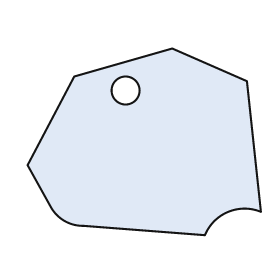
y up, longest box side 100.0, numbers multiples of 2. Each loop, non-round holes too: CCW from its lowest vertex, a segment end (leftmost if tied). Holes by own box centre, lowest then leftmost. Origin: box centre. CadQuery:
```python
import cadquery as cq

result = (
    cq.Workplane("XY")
    .moveTo(26.0, -40.0)
    .threePointArc((36.0, -30.0), (50.0, -30.0))
    .lineTo(44.0, 26.0)
    .lineTo(12.0, 40.0)
    .lineTo(-30.0, 28.0)
    .lineTo(-50.0, -10.0)
    .lineTo(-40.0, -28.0)
    .threePointArc((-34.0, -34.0), (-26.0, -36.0))
    .close()
    .moveTo(-8.0, 22.0)
    .circle(6.0)
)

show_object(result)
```